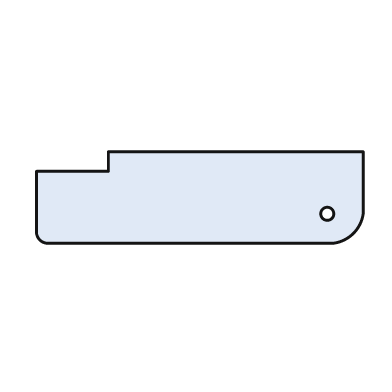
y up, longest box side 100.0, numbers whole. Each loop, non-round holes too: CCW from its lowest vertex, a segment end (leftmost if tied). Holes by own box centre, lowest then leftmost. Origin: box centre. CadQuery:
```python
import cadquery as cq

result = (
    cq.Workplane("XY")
    .moveTo(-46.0, -14.0)
    .lineTo(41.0, -14.0)
    .threePointArc((47.0, -11.0), (50.0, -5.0))
    .lineTo(50.0, 14.0)
    .lineTo(-28.0, 14.0)
    .lineTo(-28.0, 8.0)
    .lineTo(-50.0, 8.0)
    .lineTo(-50.0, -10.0)
    .threePointArc((-49.0, -13.0), (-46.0, -14.0))
    .close()
    .moveTo(39.0, -5.0)
    .circle(2.0)
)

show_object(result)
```